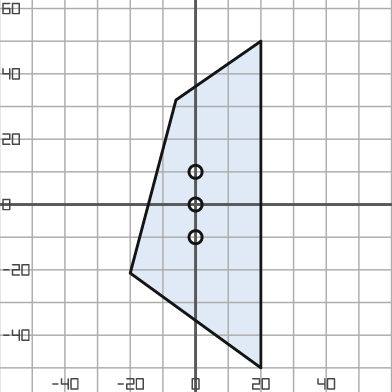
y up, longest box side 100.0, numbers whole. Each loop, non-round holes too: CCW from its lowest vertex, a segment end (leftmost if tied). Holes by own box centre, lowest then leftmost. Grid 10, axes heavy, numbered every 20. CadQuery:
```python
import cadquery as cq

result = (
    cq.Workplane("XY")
    .moveTo(20.0, -50.0)
    .lineTo(20.0, 50.0)
    .lineTo(-6.0, 32.0)
    .lineTo(-20.0, -21.0)
    .close()
    .moveTo(0.0, -10.0)
    .circle(2.0)
    .moveTo(0.0, 0.0)
    .circle(2.0)
    .moveTo(0.0, 10.0)
    .circle(2.0)
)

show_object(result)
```